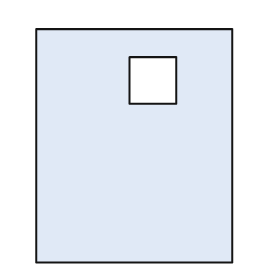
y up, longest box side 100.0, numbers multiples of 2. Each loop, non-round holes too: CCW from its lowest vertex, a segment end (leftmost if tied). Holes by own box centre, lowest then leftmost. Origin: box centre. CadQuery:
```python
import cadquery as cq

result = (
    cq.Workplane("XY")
    .moveTo(-42.0, -50.0)
    .lineTo(42.0, -50.0)
    .lineTo(42.0, 50.0)
    .lineTo(-42.0, 50.0)
    .close()
    .moveTo(-2.0, 18.0)
    .lineTo(18.0, 18.0)
    .lineTo(18.0, 38.0)
    .lineTo(-2.0, 38.0)
    .close()
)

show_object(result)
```